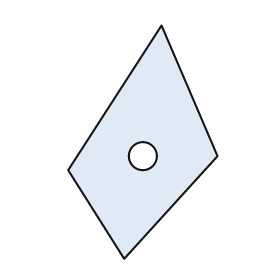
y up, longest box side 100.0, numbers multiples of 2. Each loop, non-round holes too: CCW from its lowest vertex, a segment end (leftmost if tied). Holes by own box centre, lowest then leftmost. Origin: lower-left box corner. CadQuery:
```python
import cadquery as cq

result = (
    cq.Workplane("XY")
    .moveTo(24.0, 0.0)
    .lineTo(64.0, 44.0)
    .lineTo(40.0, 100.0)
    .lineTo(0.0, 38.0)
    .close()
    .moveTo(32.0, 44.0)
    .circle(6.0)
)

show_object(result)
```